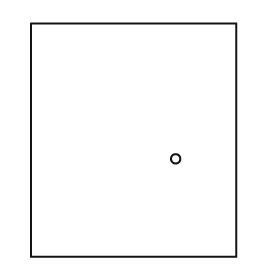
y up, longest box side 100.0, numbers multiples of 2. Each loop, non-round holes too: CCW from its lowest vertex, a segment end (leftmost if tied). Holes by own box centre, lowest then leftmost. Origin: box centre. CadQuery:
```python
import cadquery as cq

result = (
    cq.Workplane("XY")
    .moveTo(-44.0, -50.0)
    .lineTo(44.0, -50.0)
    .lineTo(44.0, 50.0)
    .lineTo(-44.0, 50.0)
    .close()
    .moveTo(18.0, -8.0)
    .circle(2.0)
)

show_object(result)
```